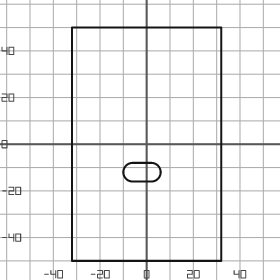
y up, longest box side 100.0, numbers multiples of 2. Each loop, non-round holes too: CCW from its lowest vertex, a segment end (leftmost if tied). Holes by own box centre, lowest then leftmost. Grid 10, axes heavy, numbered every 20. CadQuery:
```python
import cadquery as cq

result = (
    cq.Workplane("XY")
    .moveTo(-32.0, -50.0)
    .lineTo(32.0, -50.0)
    .lineTo(32.0, 50.0)
    .lineTo(-32.0, 50.0)
    .close()
    .moveTo(-6.0, -16.0)
    .lineTo(2.0, -16.0)
    .threePointArc((6.0, -12.0), (2.0, -8.0))
    .lineTo(-6.0, -8.0)
    .threePointArc((-10.0, -12.0), (-6.0, -16.0))
    .close()
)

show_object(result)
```